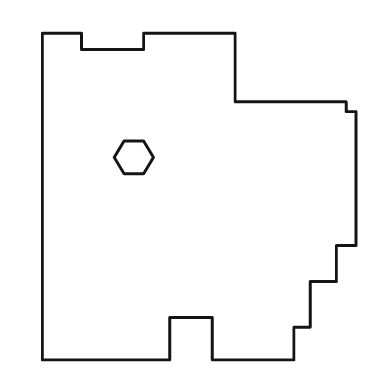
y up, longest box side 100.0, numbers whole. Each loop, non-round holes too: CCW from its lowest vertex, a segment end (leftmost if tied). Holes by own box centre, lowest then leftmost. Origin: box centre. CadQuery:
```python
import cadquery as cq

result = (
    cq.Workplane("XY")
    .moveTo(-48.0, -50.0)
    .lineTo(-9.0, -50.0)
    .lineTo(-9.0, -37.0)
    .lineTo(4.0, -37.0)
    .lineTo(4.0, -50.0)
    .lineTo(29.0, -50.0)
    .lineTo(29.0, -40.0)
    .lineTo(34.0, -40.0)
    .lineTo(34.0, -26.0)
    .lineTo(42.0, -26.0)
    .lineTo(42.0, -15.0)
    .lineTo(48.0, -15.0)
    .lineTo(48.0, 26.0)
    .lineTo(45.0, 26.0)
    .lineTo(45.0, 29.0)
    .lineTo(11.0, 29.0)
    .lineTo(11.0, 50.0)
    .lineTo(-17.0, 50.0)
    .lineTo(-17.0, 45.0)
    .lineTo(-36.0, 45.0)
    .lineTo(-36.0, 50.0)
    .lineTo(-48.0, 50.0)
    .close()
    .moveTo(-23.0, 7.0)
    .lineTo(-17.0, 7.0)
    .lineTo(-14.0, 12.0)
    .lineTo(-17.0, 17.0)
    .lineTo(-23.0, 17.0)
    .lineTo(-26.0, 12.0)
    .close()
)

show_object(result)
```